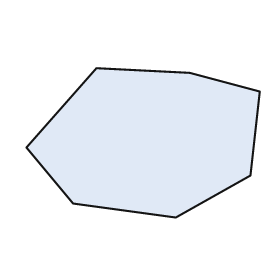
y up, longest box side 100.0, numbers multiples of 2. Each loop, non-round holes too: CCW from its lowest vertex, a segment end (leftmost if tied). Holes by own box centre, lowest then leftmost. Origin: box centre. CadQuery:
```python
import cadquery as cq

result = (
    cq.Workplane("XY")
    .moveTo(14.0, -32.0)
    .lineTo(46.0, -14.0)
    .lineTo(50.0, 22.0)
    .lineTo(20.0, 30.0)
    .lineTo(-20.0, 32.0)
    .lineTo(-50.0, -2.0)
    .lineTo(-30.0, -26.0)
    .close()
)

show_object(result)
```